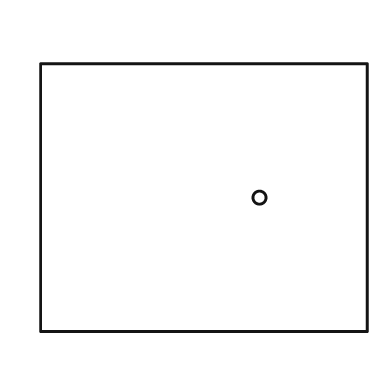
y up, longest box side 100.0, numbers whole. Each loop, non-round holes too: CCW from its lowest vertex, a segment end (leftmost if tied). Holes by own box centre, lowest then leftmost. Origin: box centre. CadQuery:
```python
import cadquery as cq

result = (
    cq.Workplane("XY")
    .moveTo(-50.0, -41.0)
    .lineTo(50.0, -41.0)
    .lineTo(50.0, 41.0)
    .lineTo(-50.0, 41.0)
    .close()
    .moveTo(17.0, 0.0)
    .circle(2.0)
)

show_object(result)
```